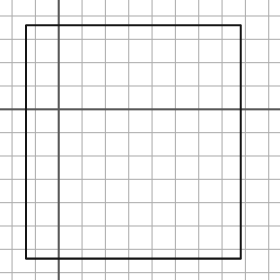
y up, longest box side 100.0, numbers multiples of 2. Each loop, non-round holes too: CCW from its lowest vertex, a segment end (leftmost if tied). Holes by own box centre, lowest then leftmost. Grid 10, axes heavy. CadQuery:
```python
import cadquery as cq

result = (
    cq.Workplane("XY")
    .moveTo(-14.0, -64.0)
    .lineTo(78.0, -64.0)
    .lineTo(78.0, 36.0)
    .lineTo(-14.0, 36.0)
    .close()
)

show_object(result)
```